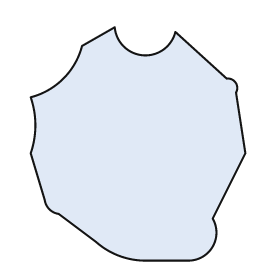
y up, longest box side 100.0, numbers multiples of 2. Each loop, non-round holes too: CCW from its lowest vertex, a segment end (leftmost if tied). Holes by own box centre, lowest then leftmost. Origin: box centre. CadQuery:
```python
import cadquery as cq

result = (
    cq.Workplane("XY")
    .moveTo(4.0, -50.0)
    .lineTo(22.0, -50.0)
    .threePointArc((32.0, -44.0), (32.0, -32.0))
    .lineTo(46.0, -4.0)
    .lineTo(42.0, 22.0)
    .threePointArc((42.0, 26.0), (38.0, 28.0))
    .lineTo(16.0, 48.0)
    .threePointArc((2.0, 38.0), (-10.0, 50.0))
    .lineTo(-24.0, 42.0)
    .threePointArc((-32.0, 28.0), (-46.0, 20.0))
    .threePointArc((-44.0, 8.0), (-46.0, -4.0))
    .lineTo(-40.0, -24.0)
    .threePointArc((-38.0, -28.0), (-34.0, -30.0))
    .lineTo(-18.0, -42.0)
    .threePointArc((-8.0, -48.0), (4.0, -50.0))
    .close()
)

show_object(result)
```